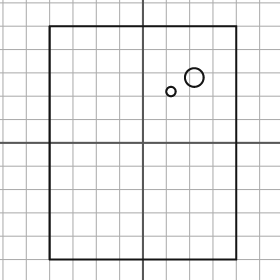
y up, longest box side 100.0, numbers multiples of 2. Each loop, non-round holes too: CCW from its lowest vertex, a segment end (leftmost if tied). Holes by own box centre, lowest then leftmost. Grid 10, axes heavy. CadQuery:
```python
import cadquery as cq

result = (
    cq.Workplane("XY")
    .moveTo(-40.0, -50.0)
    .lineTo(40.0, -50.0)
    .lineTo(40.0, 50.0)
    .lineTo(-40.0, 50.0)
    .close()
    .moveTo(12.0, 22.0)
    .circle(2.0)
    .moveTo(22.0, 28.0)
    .circle(4.0)
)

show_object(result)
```